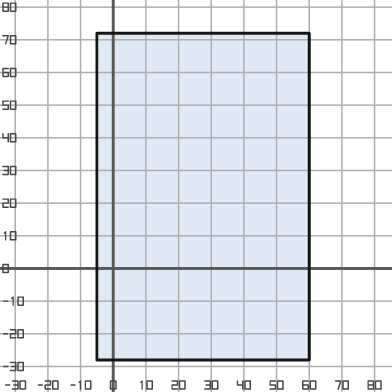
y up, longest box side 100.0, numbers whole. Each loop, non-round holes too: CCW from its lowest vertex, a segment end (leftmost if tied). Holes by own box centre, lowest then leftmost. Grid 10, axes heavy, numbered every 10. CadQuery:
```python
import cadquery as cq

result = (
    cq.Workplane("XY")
    .moveTo(-5.0, -28.0)
    .lineTo(60.0, -28.0)
    .lineTo(60.0, 72.0)
    .lineTo(-5.0, 72.0)
    .close()
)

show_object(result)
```